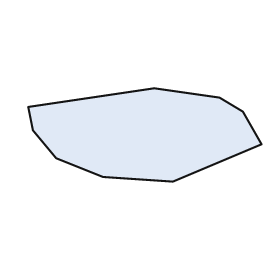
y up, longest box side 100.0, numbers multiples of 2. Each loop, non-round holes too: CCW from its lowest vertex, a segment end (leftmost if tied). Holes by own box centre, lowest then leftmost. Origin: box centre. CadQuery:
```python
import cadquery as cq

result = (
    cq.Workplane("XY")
    .moveTo(12.0, -20.0)
    .lineTo(50.0, -4.0)
    .lineTo(42.0, 10.0)
    .lineTo(32.0, 16.0)
    .lineTo(4.0, 20.0)
    .lineTo(-50.0, 12.0)
    .lineTo(-48.0, 2.0)
    .lineTo(-38.0, -10.0)
    .lineTo(-18.0, -18.0)
    .close()
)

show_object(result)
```